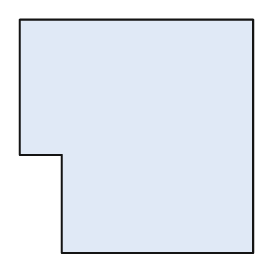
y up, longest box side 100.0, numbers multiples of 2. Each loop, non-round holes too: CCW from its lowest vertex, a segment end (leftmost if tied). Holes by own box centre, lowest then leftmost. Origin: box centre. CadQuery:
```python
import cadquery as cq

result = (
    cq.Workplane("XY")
    .moveTo(-32.0, -50.0)
    .lineTo(50.0, -50.0)
    .lineTo(50.0, 50.0)
    .lineTo(-50.0, 50.0)
    .lineTo(-50.0, -8.0)
    .lineTo(-32.0, -8.0)
    .close()
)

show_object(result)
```